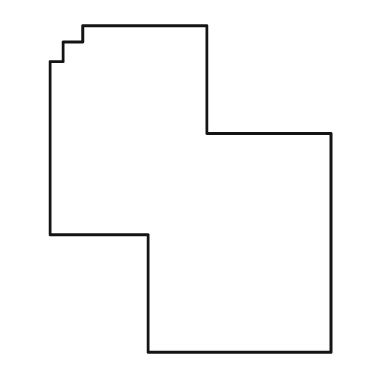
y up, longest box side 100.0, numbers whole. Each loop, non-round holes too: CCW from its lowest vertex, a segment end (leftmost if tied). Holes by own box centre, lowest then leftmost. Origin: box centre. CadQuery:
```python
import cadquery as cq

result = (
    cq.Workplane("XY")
    .moveTo(-13.0, -50.0)
    .lineTo(43.0, -50.0)
    .lineTo(43.0, 17.0)
    .lineTo(5.0, 17.0)
    .lineTo(5.0, 50.0)
    .lineTo(-33.0, 50.0)
    .lineTo(-33.0, 45.0)
    .lineTo(-39.0, 45.0)
    .lineTo(-39.0, 39.0)
    .lineTo(-43.0, 39.0)
    .lineTo(-43.0, -14.0)
    .lineTo(-13.0, -14.0)
    .close()
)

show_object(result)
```